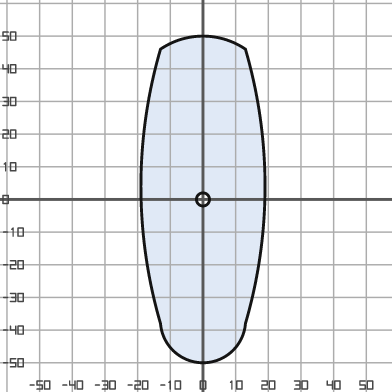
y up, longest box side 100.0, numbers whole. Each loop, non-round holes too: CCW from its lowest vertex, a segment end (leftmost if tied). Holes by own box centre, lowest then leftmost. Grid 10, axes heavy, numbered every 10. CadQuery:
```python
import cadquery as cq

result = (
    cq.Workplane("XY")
    .moveTo(-13.0, -38.0)
    .threePointArc((0.0, -50.0), (13.0, -38.0))
    .threePointArc((19.0, 4.0), (13.0, 46.0))
    .threePointArc((0.0, 50.0), (-13.0, 46.0))
    .threePointArc((-19.0, 4.0), (-13.0, -38.0))
    .close()
    .moveTo(0.0, 0.0)
    .circle(2.0)
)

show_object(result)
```